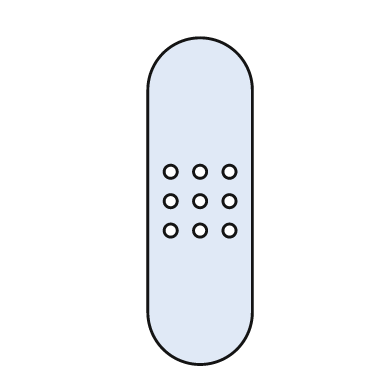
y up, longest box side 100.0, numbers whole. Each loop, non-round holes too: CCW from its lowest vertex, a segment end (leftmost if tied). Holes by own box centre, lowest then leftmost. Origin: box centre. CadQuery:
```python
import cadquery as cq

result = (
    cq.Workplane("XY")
    .moveTo(-16.0, -34.0)
    .threePointArc((0.0, -50.0), (16.0, -34.0))
    .lineTo(16.0, 34.0)
    .threePointArc((0.0, 50.0), (-16.0, 34.0))
    .close()
    .moveTo(-9.0, -9.0)
    .circle(2.0)
    .moveTo(0.0, -9.0)
    .circle(2.0)
    .moveTo(9.0, -9.0)
    .circle(2.0)
    .moveTo(-9.0, 0.0)
    .circle(2.0)
    .moveTo(0.0, 0.0)
    .circle(2.0)
    .moveTo(9.0, 0.0)
    .circle(2.0)
    .moveTo(-9.0, 9.0)
    .circle(2.0)
    .moveTo(0.0, 9.0)
    .circle(2.0)
    .moveTo(9.0, 9.0)
    .circle(2.0)
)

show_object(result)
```